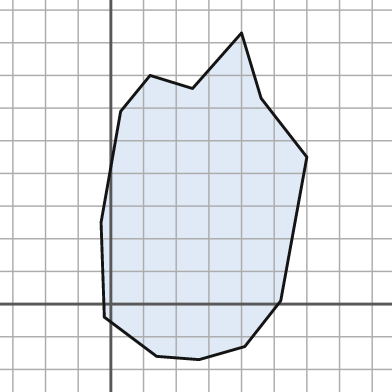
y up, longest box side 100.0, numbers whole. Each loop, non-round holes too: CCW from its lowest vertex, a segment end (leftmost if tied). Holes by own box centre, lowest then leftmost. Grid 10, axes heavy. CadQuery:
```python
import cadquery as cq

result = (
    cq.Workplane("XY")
    .moveTo(27.0, -17.0)
    .lineTo(41.0, -13.0)
    .lineTo(52.0, 1.0)
    .lineTo(60.0, 45.0)
    .lineTo(46.0, 63.0)
    .lineTo(40.0, 83.0)
    .lineTo(25.0, 66.0)
    .lineTo(12.0, 70.0)
    .lineTo(3.0, 59.0)
    .lineTo(-3.0, 25.0)
    .lineTo(-2.0, -4.0)
    .lineTo(14.0, -16.0)
    .close()
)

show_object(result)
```